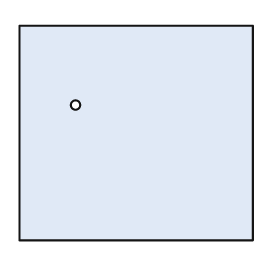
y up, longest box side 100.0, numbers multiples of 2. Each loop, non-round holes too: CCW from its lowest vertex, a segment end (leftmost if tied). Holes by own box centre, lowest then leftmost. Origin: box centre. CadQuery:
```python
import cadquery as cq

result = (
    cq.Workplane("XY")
    .moveTo(-50.0, -46.0)
    .lineTo(50.0, -46.0)
    .lineTo(50.0, 46.0)
    .lineTo(-50.0, 46.0)
    .close()
    .moveTo(-26.0, 12.0)
    .circle(2.0)
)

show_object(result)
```